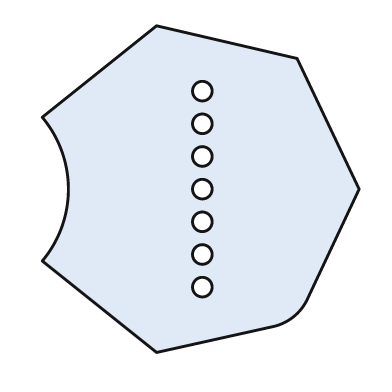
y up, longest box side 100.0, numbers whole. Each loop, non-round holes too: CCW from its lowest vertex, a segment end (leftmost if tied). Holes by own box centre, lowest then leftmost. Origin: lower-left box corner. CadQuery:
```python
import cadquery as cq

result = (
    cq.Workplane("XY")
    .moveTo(35.0, 0.0)
    .lineTo(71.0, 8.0)
    .threePointArc((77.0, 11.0), (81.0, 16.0))
    .lineTo(97.0, 50.0)
    .lineTo(78.0, 90.0)
    .lineTo(35.0, 100.0)
    .lineTo(0.0, 72.0)
    .threePointArc((8.0, 50.0), (0.0, 28.0))
    .close()
    .moveTo(49.0, 20.0)
    .circle(3.0)
    .moveTo(49.0, 30.0)
    .circle(3.0)
    .moveTo(49.0, 40.0)
    .circle(3.0)
    .moveTo(49.0, 50.0)
    .circle(3.0)
    .moveTo(49.0, 60.0)
    .circle(3.0)
    .moveTo(49.0, 70.0)
    .circle(3.0)
    .moveTo(49.0, 80.0)
    .circle(3.0)
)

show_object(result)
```